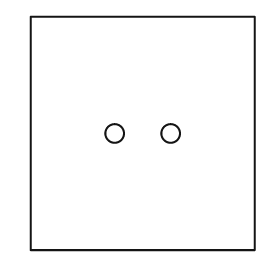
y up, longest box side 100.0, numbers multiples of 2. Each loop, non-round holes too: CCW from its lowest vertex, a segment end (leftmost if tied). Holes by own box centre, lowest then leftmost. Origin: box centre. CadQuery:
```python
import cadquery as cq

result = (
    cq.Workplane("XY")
    .moveTo(-48.0, -50.0)
    .lineTo(48.0, -50.0)
    .lineTo(48.0, 50.0)
    .lineTo(-48.0, 50.0)
    .close()
    .moveTo(-12.0, 0.0)
    .circle(4.0)
    .moveTo(12.0, 0.0)
    .circle(4.0)
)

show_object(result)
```